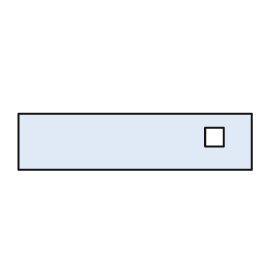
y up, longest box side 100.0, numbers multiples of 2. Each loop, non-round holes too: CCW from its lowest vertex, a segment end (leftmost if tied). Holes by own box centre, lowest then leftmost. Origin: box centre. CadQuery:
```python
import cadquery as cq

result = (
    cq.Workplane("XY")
    .moveTo(-50.0, -12.0)
    .lineTo(50.0, -12.0)
    .lineTo(50.0, 12.0)
    .lineTo(-50.0, 12.0)
    .close()
    .moveTo(30.0, -2.0)
    .lineTo(38.0, -2.0)
    .lineTo(38.0, 6.0)
    .lineTo(30.0, 6.0)
    .close()
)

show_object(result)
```